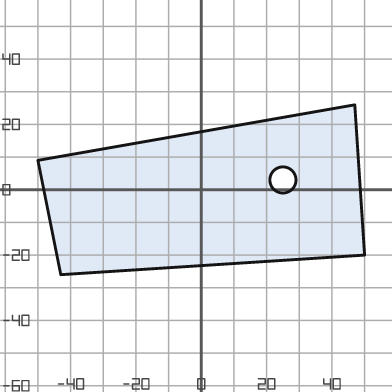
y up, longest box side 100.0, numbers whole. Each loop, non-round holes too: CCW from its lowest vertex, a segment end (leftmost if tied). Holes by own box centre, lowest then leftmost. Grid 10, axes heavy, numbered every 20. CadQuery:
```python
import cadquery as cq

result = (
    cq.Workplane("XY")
    .moveTo(-43.0, -26.0)
    .lineTo(50.0, -20.0)
    .lineTo(47.0, 26.0)
    .lineTo(-50.0, 9.0)
    .close()
    .moveTo(25.0, 3.0)
    .circle(4.0)
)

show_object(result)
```